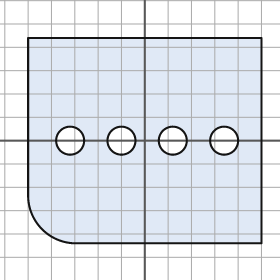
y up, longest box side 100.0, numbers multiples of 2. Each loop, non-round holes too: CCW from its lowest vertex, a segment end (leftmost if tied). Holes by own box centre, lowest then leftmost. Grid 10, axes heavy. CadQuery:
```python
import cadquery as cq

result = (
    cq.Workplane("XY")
    .moveTo(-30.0, -44.0)
    .lineTo(50.0, -44.0)
    .lineTo(50.0, 44.0)
    .lineTo(-50.0, 44.0)
    .lineTo(-50.0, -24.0)
    .threePointArc((-44.0, -38.0), (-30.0, -44.0))
    .close()
    .moveTo(-32.0, 0.0)
    .circle(6.0)
    .moveTo(-10.0, 0.0)
    .circle(6.0)
    .moveTo(12.0, 0.0)
    .circle(6.0)
    .moveTo(34.0, 0.0)
    .circle(6.0)
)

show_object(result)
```